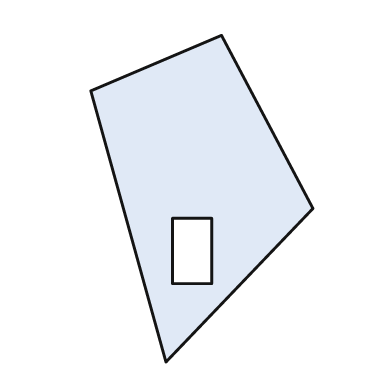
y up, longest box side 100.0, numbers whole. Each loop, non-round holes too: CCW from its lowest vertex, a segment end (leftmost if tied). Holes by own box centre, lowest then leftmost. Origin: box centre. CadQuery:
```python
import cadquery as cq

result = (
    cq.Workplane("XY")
    .moveTo(-11.0, -50.0)
    .lineTo(34.0, -3.0)
    .lineTo(6.0, 50.0)
    .lineTo(-34.0, 33.0)
    .close()
    .moveTo(-9.0, -26.0)
    .lineTo(3.0, -26.0)
    .lineTo(3.0, -6.0)
    .lineTo(-9.0, -6.0)
    .close()
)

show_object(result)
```